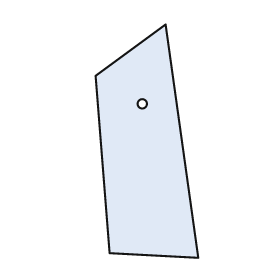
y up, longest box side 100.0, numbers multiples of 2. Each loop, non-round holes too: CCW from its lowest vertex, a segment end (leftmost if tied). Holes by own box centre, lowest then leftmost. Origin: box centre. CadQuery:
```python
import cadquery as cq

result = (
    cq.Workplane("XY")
    .moveTo(22.0, -50.0)
    .lineTo(8.0, 50.0)
    .lineTo(-22.0, 28.0)
    .lineTo(-16.0, -48.0)
    .close()
    .moveTo(-2.0, 16.0)
    .circle(2.0)
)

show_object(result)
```